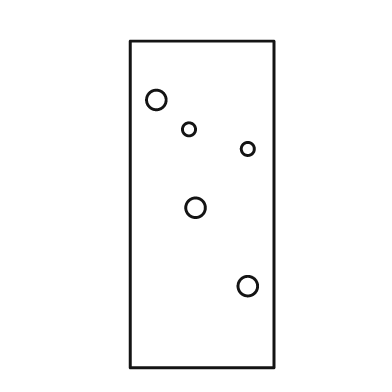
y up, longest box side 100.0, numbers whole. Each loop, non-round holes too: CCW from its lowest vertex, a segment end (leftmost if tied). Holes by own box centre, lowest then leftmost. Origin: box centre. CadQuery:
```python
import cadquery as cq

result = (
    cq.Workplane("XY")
    .moveTo(-22.0, -50.0)
    .lineTo(22.0, -50.0)
    .lineTo(22.0, 50.0)
    .lineTo(-22.0, 50.0)
    .close()
    .moveTo(14.0, -25.0)
    .circle(3.0)
    .moveTo(-2.0, -1.0)
    .circle(3.0)
    .moveTo(14.0, 17.0)
    .circle(2.0)
    .moveTo(-4.0, 23.0)
    .circle(2.0)
    .moveTo(-14.0, 32.0)
    .circle(3.0)
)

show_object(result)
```